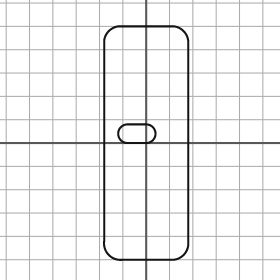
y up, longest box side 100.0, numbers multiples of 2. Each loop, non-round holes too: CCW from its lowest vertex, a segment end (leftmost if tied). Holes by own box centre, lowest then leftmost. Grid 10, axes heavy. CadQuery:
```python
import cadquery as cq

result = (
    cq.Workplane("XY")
    .moveTo(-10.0, -50.0)
    .lineTo(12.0, -50.0)
    .threePointArc((16.0, -48.0), (18.0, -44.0))
    .lineTo(18.0, 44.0)
    .threePointArc((16.0, 48.0), (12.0, 50.0))
    .lineTo(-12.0, 50.0)
    .threePointArc((-16.0, 48.0), (-18.0, 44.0))
    .lineTo(-18.0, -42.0)
    .threePointArc((-16.0, -48.0), (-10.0, -50.0))
    .close()
    .moveTo(-8.0, 0.0)
    .lineTo(0.0, 0.0)
    .threePointArc((4.0, 4.0), (0.0, 8.0))
    .lineTo(-8.0, 8.0)
    .threePointArc((-12.0, 4.0), (-8.0, 0.0))
    .close()
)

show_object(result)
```